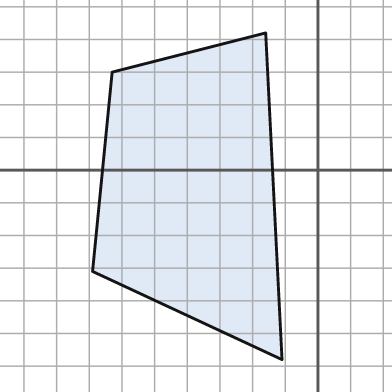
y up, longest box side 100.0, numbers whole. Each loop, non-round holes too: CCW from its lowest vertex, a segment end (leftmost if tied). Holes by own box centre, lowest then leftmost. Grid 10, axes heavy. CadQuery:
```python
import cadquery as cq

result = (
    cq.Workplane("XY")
    .moveTo(-11.0, -58.0)
    .lineTo(-16.0, 42.0)
    .lineTo(-63.0, 30.0)
    .lineTo(-69.0, -31.0)
    .close()
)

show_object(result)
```